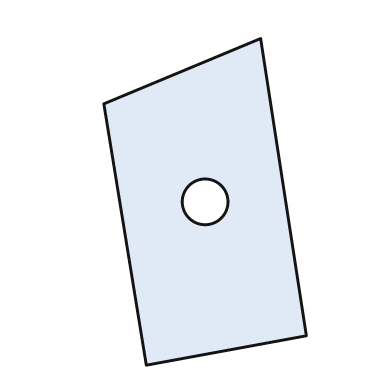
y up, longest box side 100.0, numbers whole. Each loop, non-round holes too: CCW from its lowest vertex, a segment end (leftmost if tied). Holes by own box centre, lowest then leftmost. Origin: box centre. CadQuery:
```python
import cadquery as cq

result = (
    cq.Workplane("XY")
    .moveTo(-18.0, -50.0)
    .lineTo(31.0, -41.0)
    .lineTo(17.0, 50.0)
    .lineTo(-31.0, 30.0)
    .close()
    .moveTo(0.0, 0.0)
    .circle(7.0)
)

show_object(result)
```